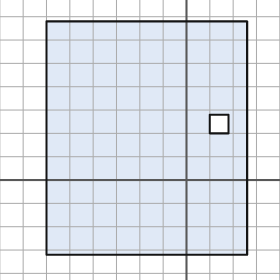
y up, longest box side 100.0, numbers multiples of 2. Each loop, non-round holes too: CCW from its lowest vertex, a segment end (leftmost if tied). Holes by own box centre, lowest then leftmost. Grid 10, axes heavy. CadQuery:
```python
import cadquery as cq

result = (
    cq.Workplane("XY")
    .moveTo(-60.0, -32.0)
    .lineTo(26.0, -32.0)
    .lineTo(26.0, 68.0)
    .lineTo(-60.0, 68.0)
    .close()
    .moveTo(10.0, 20.0)
    .lineTo(18.0, 20.0)
    .lineTo(18.0, 28.0)
    .lineTo(10.0, 28.0)
    .close()
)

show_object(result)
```